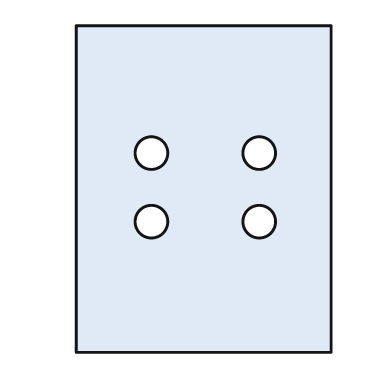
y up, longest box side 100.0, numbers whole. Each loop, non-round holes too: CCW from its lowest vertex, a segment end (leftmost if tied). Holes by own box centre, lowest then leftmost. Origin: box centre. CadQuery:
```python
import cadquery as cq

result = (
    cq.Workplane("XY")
    .moveTo(-39.0, -50.0)
    .lineTo(39.0, -50.0)
    .lineTo(39.0, 50.0)
    .lineTo(-39.0, 50.0)
    .close()
    .moveTo(-16.0, -10.0)
    .circle(5.0)
    .moveTo(17.0, -10.0)
    .circle(5.0)
    .moveTo(-16.0, 11.0)
    .circle(5.0)
    .moveTo(17.0, 11.0)
    .circle(5.0)
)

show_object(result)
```